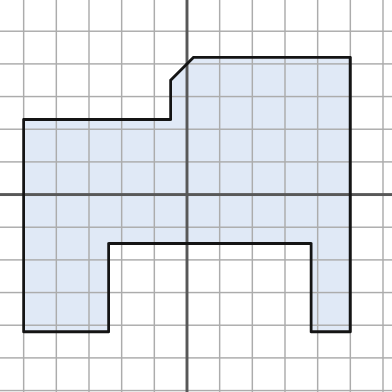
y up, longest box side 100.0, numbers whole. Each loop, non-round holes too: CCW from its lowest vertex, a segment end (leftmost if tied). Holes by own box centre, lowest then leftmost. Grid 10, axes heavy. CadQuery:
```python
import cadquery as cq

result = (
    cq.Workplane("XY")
    .moveTo(-50.0, -42.0)
    .lineTo(-24.0, -42.0)
    .lineTo(-24.0, -15.0)
    .lineTo(38.0, -15.0)
    .lineTo(38.0, -42.0)
    .lineTo(50.0, -42.0)
    .lineTo(50.0, 42.0)
    .lineTo(2.0, 42.0)
    .lineTo(-5.0, 35.0)
    .lineTo(-5.0, 23.0)
    .lineTo(-50.0, 23.0)
    .close()
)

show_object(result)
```